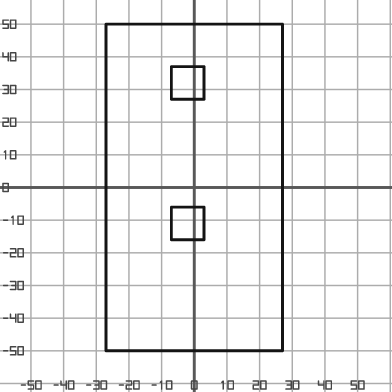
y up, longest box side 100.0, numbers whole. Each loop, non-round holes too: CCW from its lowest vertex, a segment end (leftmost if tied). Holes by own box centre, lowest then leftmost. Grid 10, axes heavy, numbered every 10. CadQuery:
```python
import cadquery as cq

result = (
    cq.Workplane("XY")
    .moveTo(-27.0, -50.0)
    .lineTo(27.0, -50.0)
    .lineTo(27.0, 50.0)
    .lineTo(-27.0, 50.0)
    .close()
    .moveTo(-7.0, -16.0)
    .lineTo(3.0, -16.0)
    .lineTo(3.0, -6.0)
    .lineTo(-7.0, -6.0)
    .close()
    .moveTo(-7.0, 27.0)
    .lineTo(3.0, 27.0)
    .lineTo(3.0, 37.0)
    .lineTo(-7.0, 37.0)
    .close()
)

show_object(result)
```